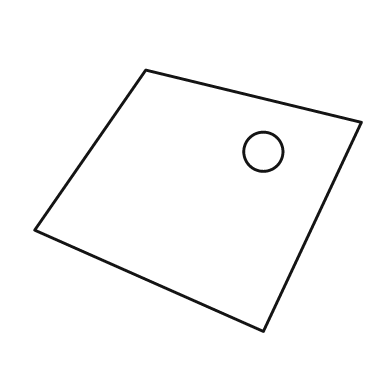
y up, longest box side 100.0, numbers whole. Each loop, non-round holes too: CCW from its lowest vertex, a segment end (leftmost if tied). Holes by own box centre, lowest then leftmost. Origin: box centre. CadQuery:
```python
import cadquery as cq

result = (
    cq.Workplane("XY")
    .moveTo(20.0, -40.0)
    .lineTo(50.0, 24.0)
    .lineTo(-16.0, 40.0)
    .lineTo(-50.0, -9.0)
    .close()
    .moveTo(20.0, 15.0)
    .circle(6.0)
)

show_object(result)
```